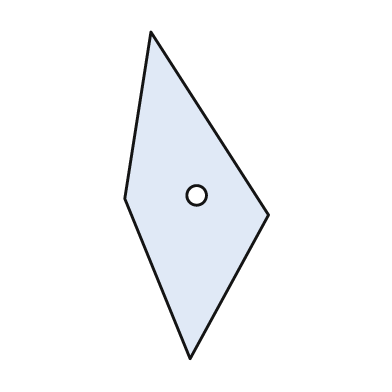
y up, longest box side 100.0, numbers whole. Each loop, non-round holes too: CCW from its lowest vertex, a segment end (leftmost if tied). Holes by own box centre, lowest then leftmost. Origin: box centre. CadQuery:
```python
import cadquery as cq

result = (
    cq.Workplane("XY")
    .moveTo(-2.0, -50.0)
    .lineTo(22.0, -6.0)
    .lineTo(-14.0, 50.0)
    .lineTo(-22.0, -1.0)
    .close()
    .moveTo(0.0, 0.0)
    .circle(3.0)
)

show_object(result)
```